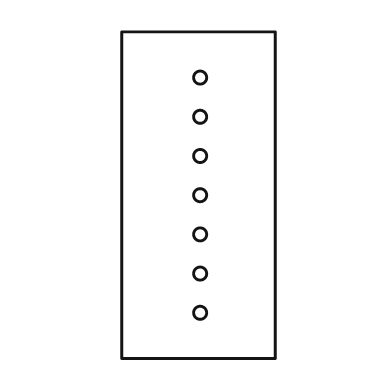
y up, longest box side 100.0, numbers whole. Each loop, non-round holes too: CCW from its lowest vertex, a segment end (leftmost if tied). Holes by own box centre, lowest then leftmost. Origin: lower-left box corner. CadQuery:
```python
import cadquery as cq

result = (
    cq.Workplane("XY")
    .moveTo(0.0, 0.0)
    .lineTo(47.0, 0.0)
    .lineTo(47.0, 100.0)
    .lineTo(0.0, 100.0)
    .close()
    .moveTo(24.0, 14.0)
    .circle(2.0)
    .moveTo(24.0, 26.0)
    .circle(2.0)
    .moveTo(24.0, 38.0)
    .circle(2.0)
    .moveTo(24.0, 50.0)
    .circle(2.0)
    .moveTo(24.0, 62.0)
    .circle(2.0)
    .moveTo(24.0, 74.0)
    .circle(2.0)
    .moveTo(24.0, 86.0)
    .circle(2.0)
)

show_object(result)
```